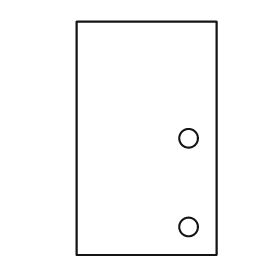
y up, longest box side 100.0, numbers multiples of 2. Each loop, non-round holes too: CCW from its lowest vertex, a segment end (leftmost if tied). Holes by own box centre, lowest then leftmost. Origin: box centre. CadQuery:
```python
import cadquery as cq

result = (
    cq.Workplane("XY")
    .moveTo(-30.0, -50.0)
    .lineTo(30.0, -50.0)
    .lineTo(30.0, 50.0)
    .lineTo(-30.0, 50.0)
    .close()
    .moveTo(18.0, -38.0)
    .circle(4.0)
    .moveTo(18.0, 0.0)
    .circle(4.0)
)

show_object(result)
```